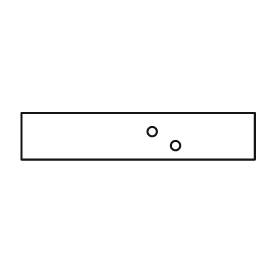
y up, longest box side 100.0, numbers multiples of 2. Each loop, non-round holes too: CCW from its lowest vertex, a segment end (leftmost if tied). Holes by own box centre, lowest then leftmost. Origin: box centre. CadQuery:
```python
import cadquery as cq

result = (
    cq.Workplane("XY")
    .moveTo(-50.0, -10.0)
    .lineTo(50.0, -10.0)
    .lineTo(50.0, 10.0)
    .lineTo(-50.0, 10.0)
    .close()
    .moveTo(16.0, -4.0)
    .circle(2.0)
    .moveTo(6.0, 2.0)
    .circle(2.0)
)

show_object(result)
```